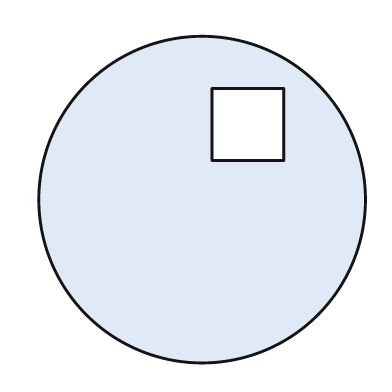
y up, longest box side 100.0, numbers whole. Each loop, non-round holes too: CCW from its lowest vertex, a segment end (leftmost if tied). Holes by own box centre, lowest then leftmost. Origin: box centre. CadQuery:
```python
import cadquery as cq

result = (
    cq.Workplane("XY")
    .moveTo(0.0, 0.0)
    .circle(50.0)
    .moveTo(3.0, 12.0)
    .lineTo(25.0, 12.0)
    .lineTo(25.0, 34.0)
    .lineTo(3.0, 34.0)
    .close()
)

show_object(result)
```